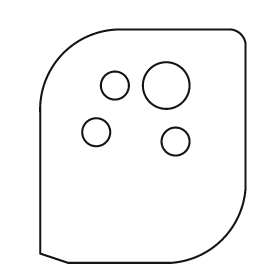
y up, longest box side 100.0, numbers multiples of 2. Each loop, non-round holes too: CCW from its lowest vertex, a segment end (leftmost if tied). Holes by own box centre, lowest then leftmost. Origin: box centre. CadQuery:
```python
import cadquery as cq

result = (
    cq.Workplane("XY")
    .moveTo(-32.0, -50.0)
    .lineTo(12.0, -50.0)
    .threePointArc((34.0, -40.0), (44.0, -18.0))
    .lineTo(44.0, 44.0)
    .threePointArc((42.0, 48.0), (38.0, 50.0))
    .lineTo(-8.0, 50.0)
    .threePointArc((-34.0, 40.0), (-44.0, 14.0))
    .lineTo(-44.0, -46.0)
    .close()
    .moveTo(14.0, 2.0)
    .circle(6.0)
    .moveTo(-20.0, 6.0)
    .circle(6.0)
    .moveTo(-12.0, 26.0)
    .circle(6.0)
    .moveTo(10.0, 26.0)
    .circle(10.0)
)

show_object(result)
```